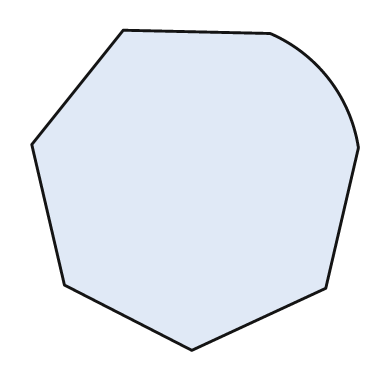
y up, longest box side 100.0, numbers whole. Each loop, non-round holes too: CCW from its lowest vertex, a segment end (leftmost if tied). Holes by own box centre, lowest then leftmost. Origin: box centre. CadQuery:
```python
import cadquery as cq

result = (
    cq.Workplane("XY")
    .moveTo(-1.0, -49.0)
    .lineTo(40.0, -30.0)
    .lineTo(50.0, 13.0)
    .threePointArc((41.0, 34.0), (23.0, 48.0))
    .lineTo(-22.0, 49.0)
    .lineTo(-50.0, 14.0)
    .lineTo(-40.0, -29.0)
    .close()
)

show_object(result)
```